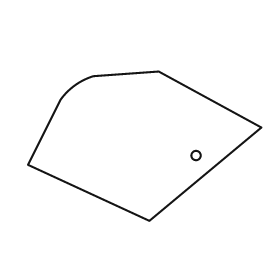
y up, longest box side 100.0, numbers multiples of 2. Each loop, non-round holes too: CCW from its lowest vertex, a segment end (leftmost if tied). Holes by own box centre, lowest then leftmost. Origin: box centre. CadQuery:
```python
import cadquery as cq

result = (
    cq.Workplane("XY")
    .moveTo(2.0, -32.0)
    .lineTo(50.0, 8.0)
    .lineTo(6.0, 32.0)
    .lineTo(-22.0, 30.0)
    .threePointArc((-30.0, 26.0), (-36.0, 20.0))
    .lineTo(-50.0, -8.0)
    .close()
    .moveTo(22.0, -4.0)
    .circle(2.0)
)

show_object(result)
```